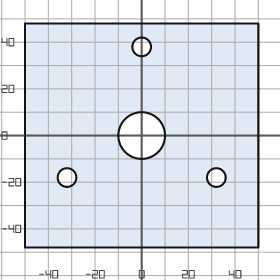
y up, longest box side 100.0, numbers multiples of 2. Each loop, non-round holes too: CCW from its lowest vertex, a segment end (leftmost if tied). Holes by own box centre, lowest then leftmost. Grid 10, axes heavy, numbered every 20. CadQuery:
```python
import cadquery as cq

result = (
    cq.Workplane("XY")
    .moveTo(-50.0, -48.0)
    .lineTo(50.0, -48.0)
    .lineTo(50.0, 48.0)
    .lineTo(-50.0, 48.0)
    .close()
    .moveTo(-32.0, -18.0)
    .circle(4.0)
    .moveTo(32.0, -18.0)
    .circle(4.0)
    .moveTo(0.0, 0.0)
    .circle(10.0)
    .moveTo(0.0, 38.0)
    .circle(4.0)
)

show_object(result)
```